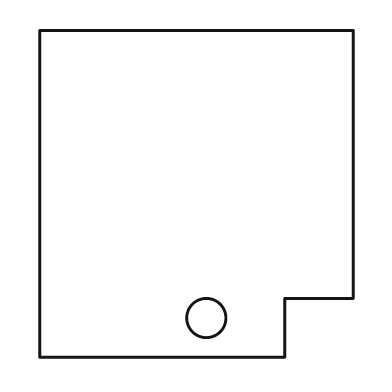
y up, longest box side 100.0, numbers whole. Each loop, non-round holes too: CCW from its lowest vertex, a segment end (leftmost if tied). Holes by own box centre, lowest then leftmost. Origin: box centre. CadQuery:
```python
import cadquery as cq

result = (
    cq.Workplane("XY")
    .moveTo(-48.0, -50.0)
    .lineTo(27.0, -50.0)
    .lineTo(27.0, -32.0)
    .lineTo(48.0, -32.0)
    .lineTo(48.0, 50.0)
    .lineTo(-48.0, 50.0)
    .close()
    .moveTo(3.0, -38.0)
    .circle(6.0)
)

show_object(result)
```